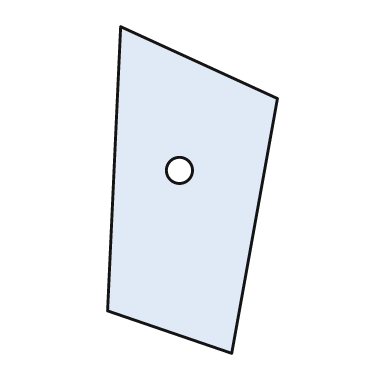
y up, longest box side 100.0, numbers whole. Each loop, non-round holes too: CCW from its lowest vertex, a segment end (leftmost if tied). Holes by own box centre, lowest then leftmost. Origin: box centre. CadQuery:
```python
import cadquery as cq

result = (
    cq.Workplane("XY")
    .moveTo(12.0, -50.0)
    .lineTo(26.0, 28.0)
    .lineTo(-22.0, 50.0)
    .lineTo(-26.0, -37.0)
    .close()
    .moveTo(-4.0, 6.0)
    .circle(4.0)
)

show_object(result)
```